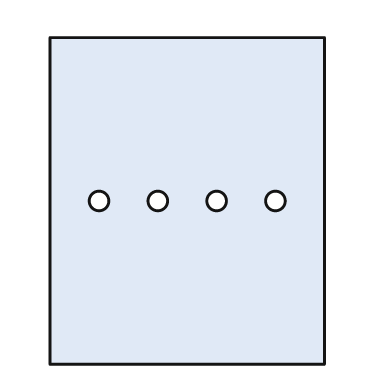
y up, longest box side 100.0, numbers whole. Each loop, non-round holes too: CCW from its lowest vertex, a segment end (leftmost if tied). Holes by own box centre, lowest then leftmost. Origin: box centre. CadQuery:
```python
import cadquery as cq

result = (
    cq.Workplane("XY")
    .moveTo(-42.0, -50.0)
    .lineTo(42.0, -50.0)
    .lineTo(42.0, 50.0)
    .lineTo(-42.0, 50.0)
    .close()
    .moveTo(-27.0, 0.0)
    .circle(3.0)
    .moveTo(-9.0, 0.0)
    .circle(3.0)
    .moveTo(9.0, 0.0)
    .circle(3.0)
    .moveTo(27.0, 0.0)
    .circle(3.0)
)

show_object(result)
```